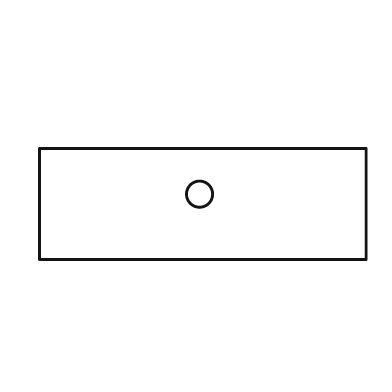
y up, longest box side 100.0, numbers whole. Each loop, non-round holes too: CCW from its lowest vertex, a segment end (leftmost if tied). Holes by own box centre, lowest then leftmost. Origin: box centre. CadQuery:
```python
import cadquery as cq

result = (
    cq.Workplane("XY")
    .moveTo(-50.0, -17.0)
    .lineTo(50.0, -17.0)
    .lineTo(50.0, 17.0)
    .lineTo(-50.0, 17.0)
    .close()
    .moveTo(-1.0, 3.0)
    .circle(4.0)
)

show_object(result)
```